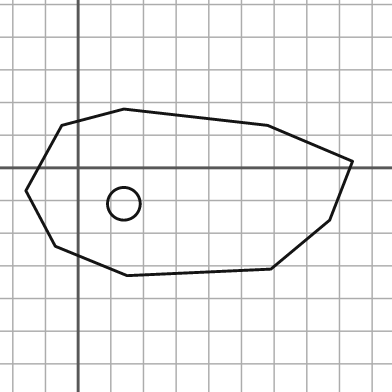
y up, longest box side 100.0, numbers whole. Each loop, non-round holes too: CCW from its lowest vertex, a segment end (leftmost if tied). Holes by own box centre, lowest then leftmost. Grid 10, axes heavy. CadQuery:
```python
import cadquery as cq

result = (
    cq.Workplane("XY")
    .moveTo(15.0, -33.0)
    .lineTo(59.0, -31.0)
    .lineTo(77.0, -16.0)
    .lineTo(84.0, 2.0)
    .lineTo(58.0, 13.0)
    .lineTo(14.0, 18.0)
    .lineTo(-5.0, 13.0)
    .lineTo(-16.0, -7.0)
    .lineTo(-7.0, -24.0)
    .close()
    .moveTo(14.0, -11.0)
    .circle(5.0)
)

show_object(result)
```